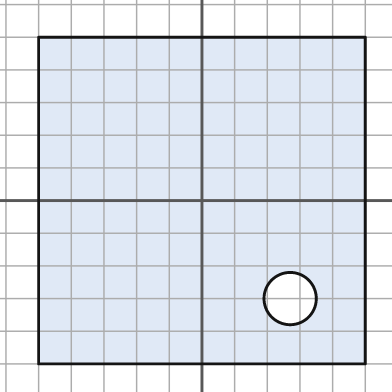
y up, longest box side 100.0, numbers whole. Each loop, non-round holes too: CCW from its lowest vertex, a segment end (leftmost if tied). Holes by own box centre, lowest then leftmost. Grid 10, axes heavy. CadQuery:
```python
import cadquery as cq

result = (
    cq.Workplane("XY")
    .moveTo(-50.0, -50.0)
    .lineTo(50.0, -50.0)
    .lineTo(50.0, 50.0)
    .lineTo(-50.0, 50.0)
    .close()
    .moveTo(27.0, -30.0)
    .circle(8.0)
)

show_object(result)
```